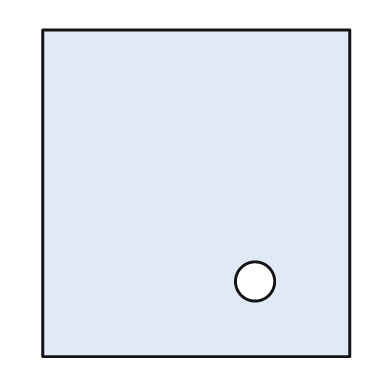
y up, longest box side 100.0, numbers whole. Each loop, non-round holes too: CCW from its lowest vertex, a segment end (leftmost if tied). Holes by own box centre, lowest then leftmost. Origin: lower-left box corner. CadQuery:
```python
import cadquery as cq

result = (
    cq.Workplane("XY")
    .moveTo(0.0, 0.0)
    .lineTo(94.0, 0.0)
    .lineTo(94.0, 100.0)
    .lineTo(0.0, 100.0)
    .close()
    .moveTo(65.0, 23.0)
    .circle(6.0)
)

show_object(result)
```